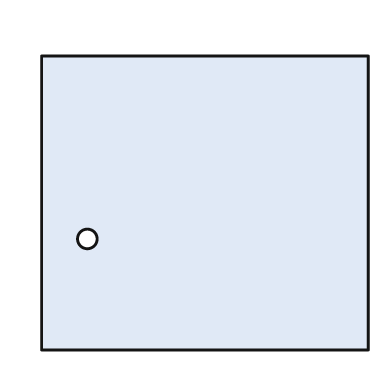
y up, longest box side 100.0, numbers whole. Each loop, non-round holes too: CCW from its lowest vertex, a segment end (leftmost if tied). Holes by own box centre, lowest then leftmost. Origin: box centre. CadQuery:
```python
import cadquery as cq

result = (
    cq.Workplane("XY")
    .moveTo(-50.0, -45.0)
    .lineTo(50.0, -45.0)
    .lineTo(50.0, 45.0)
    .lineTo(-50.0, 45.0)
    .close()
    .moveTo(-36.0, -11.0)
    .circle(3.0)
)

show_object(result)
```